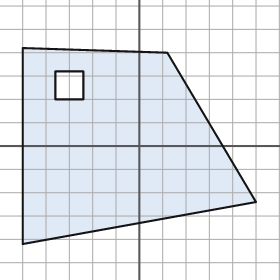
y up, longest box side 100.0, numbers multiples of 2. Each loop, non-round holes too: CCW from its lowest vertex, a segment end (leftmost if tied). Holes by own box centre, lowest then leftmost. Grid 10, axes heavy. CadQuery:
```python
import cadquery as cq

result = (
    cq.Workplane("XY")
    .moveTo(-50.0, -42.0)
    .lineTo(50.0, -24.0)
    .lineTo(12.0, 40.0)
    .lineTo(-50.0, 42.0)
    .close()
    .moveTo(-36.0, 20.0)
    .lineTo(-24.0, 20.0)
    .lineTo(-24.0, 32.0)
    .lineTo(-36.0, 32.0)
    .close()
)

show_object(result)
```